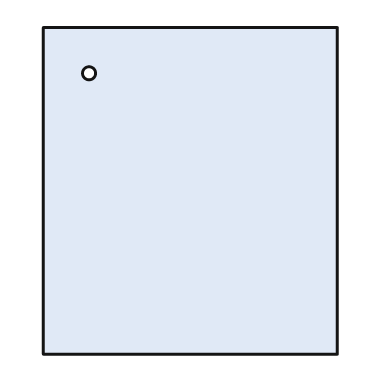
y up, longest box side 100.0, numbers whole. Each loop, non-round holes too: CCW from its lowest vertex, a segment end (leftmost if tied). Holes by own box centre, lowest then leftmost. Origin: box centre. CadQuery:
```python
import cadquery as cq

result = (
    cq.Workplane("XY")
    .moveTo(-45.0, -50.0)
    .lineTo(45.0, -50.0)
    .lineTo(45.0, 50.0)
    .lineTo(-45.0, 50.0)
    .close()
    .moveTo(-31.0, 36.0)
    .circle(2.0)
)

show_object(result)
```